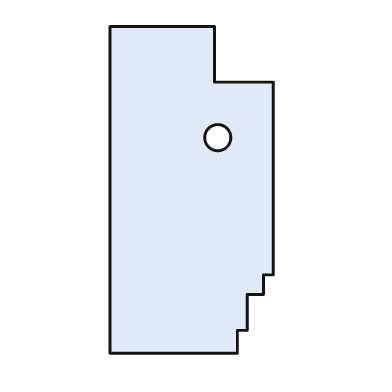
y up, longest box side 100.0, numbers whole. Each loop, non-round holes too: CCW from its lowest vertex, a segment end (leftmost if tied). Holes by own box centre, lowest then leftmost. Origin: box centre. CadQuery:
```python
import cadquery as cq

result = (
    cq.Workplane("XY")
    .moveTo(-25.0, -50.0)
    .lineTo(14.0, -50.0)
    .lineTo(14.0, -43.0)
    .lineTo(17.0, -43.0)
    .lineTo(17.0, -32.0)
    .lineTo(22.0, -32.0)
    .lineTo(22.0, -26.0)
    .lineTo(25.0, -26.0)
    .lineTo(25.0, 33.0)
    .lineTo(7.0, 33.0)
    .lineTo(7.0, 50.0)
    .lineTo(-25.0, 50.0)
    .close()
    .moveTo(8.0, 16.0)
    .circle(4.0)
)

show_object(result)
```